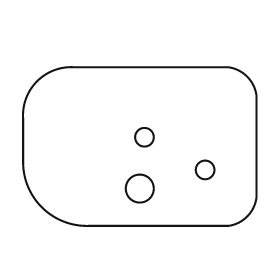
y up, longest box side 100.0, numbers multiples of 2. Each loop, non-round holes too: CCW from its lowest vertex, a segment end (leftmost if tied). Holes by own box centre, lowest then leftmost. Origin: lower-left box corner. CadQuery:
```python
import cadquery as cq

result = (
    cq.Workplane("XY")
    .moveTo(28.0, 0.0)
    .lineTo(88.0, 0.0)
    .threePointArc((96.0, 4.0), (100.0, 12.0))
    .lineTo(100.0, 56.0)
    .threePointArc((96.0, 64.0), (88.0, 68.0))
    .lineTo(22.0, 68.0)
    .threePointArc((6.0, 62.0), (0.0, 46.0))
    .lineTo(0.0, 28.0)
    .threePointArc((8.0, 8.0), (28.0, 0.0))
    .close()
    .moveTo(50.0, 16.0)
    .circle(6.0)
    .moveTo(78.0, 24.0)
    .circle(4.0)
    .moveTo(52.0, 38.0)
    .circle(4.0)
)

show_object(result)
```